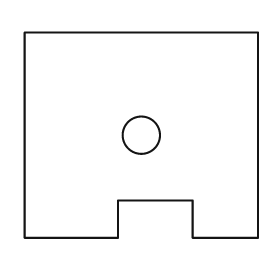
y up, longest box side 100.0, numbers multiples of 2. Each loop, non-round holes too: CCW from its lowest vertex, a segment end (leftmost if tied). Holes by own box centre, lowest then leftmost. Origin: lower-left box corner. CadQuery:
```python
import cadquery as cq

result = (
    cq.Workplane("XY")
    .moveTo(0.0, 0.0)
    .lineTo(40.0, 0.0)
    .lineTo(40.0, 16.0)
    .lineTo(72.0, 16.0)
    .lineTo(72.0, 0.0)
    .lineTo(100.0, 0.0)
    .lineTo(100.0, 88.0)
    .lineTo(0.0, 88.0)
    .close()
    .moveTo(50.0, 44.0)
    .circle(8.0)
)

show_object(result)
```